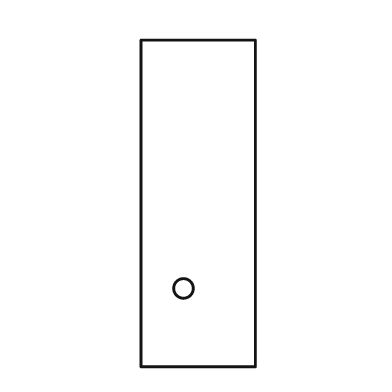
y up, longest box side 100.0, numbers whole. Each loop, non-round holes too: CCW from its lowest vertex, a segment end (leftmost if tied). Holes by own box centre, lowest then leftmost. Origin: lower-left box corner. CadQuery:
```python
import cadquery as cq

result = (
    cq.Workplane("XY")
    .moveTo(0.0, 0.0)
    .lineTo(35.0, 0.0)
    .lineTo(35.0, 100.0)
    .lineTo(0.0, 100.0)
    .close()
    .moveTo(13.0, 24.0)
    .circle(3.0)
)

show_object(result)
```